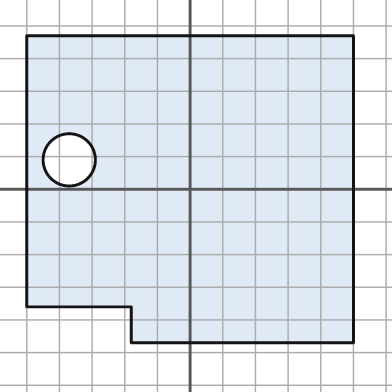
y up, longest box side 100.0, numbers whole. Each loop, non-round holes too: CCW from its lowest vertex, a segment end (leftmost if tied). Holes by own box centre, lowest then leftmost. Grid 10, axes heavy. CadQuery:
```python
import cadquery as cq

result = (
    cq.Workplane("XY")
    .moveTo(-18.0, -47.0)
    .lineTo(50.0, -47.0)
    .lineTo(50.0, 47.0)
    .lineTo(-50.0, 47.0)
    .lineTo(-50.0, -36.0)
    .lineTo(-18.0, -36.0)
    .close()
    .moveTo(-37.0, 9.0)
    .circle(8.0)
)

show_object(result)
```